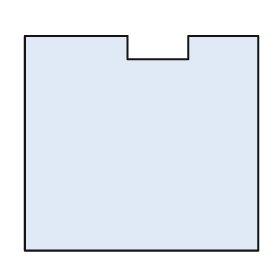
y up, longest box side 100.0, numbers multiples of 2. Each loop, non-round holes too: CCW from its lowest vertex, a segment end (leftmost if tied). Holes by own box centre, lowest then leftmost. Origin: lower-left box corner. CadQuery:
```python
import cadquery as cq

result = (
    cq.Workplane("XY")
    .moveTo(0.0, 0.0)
    .lineTo(100.0, 0.0)
    .lineTo(100.0, 92.0)
    .lineTo(70.0, 92.0)
    .lineTo(70.0, 82.0)
    .lineTo(44.0, 82.0)
    .lineTo(44.0, 92.0)
    .lineTo(0.0, 92.0)
    .close()
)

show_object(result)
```